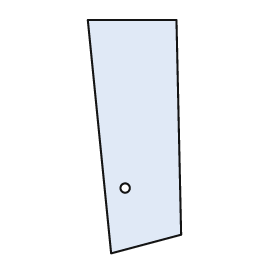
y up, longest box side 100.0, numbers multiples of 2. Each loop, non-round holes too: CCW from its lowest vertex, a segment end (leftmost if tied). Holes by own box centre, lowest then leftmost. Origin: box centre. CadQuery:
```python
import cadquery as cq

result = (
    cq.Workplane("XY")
    .moveTo(-10.0, -50.0)
    .lineTo(20.0, -42.0)
    .lineTo(18.0, 50.0)
    .lineTo(-20.0, 50.0)
    .close()
    .moveTo(-4.0, -22.0)
    .circle(2.0)
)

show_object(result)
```